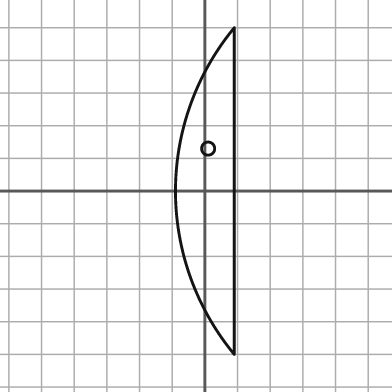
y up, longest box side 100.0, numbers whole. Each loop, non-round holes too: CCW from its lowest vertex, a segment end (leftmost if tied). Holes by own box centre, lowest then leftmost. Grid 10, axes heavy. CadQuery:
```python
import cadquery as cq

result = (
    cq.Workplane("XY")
    .moveTo(9.0, -50.0)
    .lineTo(9.0, 50.0)
    .threePointArc((-9.0, 0.0), (9.0, -50.0))
    .close()
    .moveTo(1.0, 13.0)
    .circle(2.0)
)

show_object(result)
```